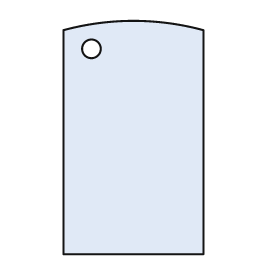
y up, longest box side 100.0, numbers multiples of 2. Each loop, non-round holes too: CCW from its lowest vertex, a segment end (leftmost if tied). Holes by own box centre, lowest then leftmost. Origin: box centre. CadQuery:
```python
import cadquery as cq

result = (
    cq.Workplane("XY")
    .moveTo(-30.0, -50.0)
    .lineTo(30.0, -50.0)
    .lineTo(30.0, 46.0)
    .threePointArc((0.0, 50.0), (-30.0, 46.0))
    .close()
    .moveTo(-18.0, 38.0)
    .circle(4.0)
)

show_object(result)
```